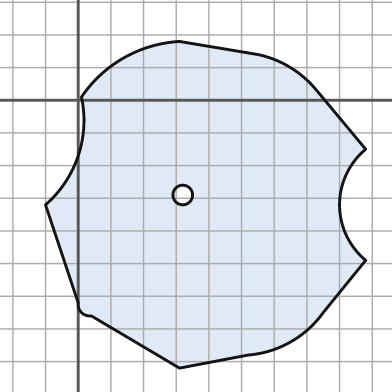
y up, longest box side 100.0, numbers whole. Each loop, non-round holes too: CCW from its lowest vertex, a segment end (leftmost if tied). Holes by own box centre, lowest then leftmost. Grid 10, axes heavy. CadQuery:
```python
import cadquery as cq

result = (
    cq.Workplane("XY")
    .moveTo(31.0, -82.0)
    .lineTo(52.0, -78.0)
    .threePointArc((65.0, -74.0), (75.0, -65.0))
    .lineTo(88.0, -49.0)
    .threePointArc((80.0, -32.0), (88.0, -15.0))
    .lineTo(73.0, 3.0)
    .threePointArc((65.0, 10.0), (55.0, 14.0))
    .lineTo(31.0, 18.0)
    .threePointArc((14.0, 13.0), (1.0, 1.0))
    .threePointArc((0.0, -17.0), (-10.0, -32.0))
    .lineTo(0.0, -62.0)
    .threePointArc((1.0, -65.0), (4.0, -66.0))
    .close()
    .moveTo(32.0, -29.0)
    .circle(3.0)
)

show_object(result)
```